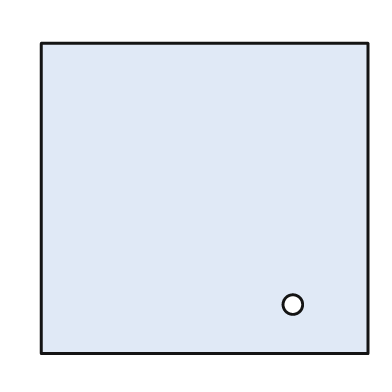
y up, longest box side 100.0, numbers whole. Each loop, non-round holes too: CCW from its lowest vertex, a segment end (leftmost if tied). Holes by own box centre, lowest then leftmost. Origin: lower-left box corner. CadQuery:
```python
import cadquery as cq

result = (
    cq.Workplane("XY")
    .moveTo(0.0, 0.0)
    .lineTo(100.0, 0.0)
    .lineTo(100.0, 95.0)
    .lineTo(0.0, 95.0)
    .close()
    .moveTo(77.0, 15.0)
    .circle(3.0)
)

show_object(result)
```